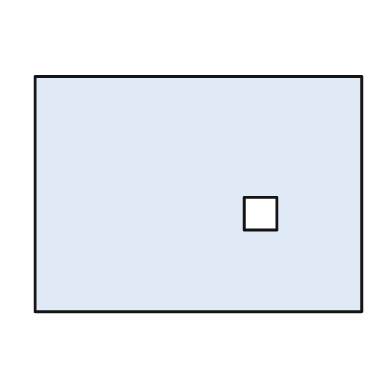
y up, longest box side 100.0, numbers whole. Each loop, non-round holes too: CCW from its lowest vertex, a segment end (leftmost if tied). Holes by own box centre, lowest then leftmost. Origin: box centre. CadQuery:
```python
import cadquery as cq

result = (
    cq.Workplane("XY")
    .moveTo(-50.0, -36.0)
    .lineTo(50.0, -36.0)
    .lineTo(50.0, 36.0)
    .lineTo(-50.0, 36.0)
    .close()
    .moveTo(14.0, -11.0)
    .lineTo(24.0, -11.0)
    .lineTo(24.0, -1.0)
    .lineTo(14.0, -1.0)
    .close()
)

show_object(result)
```